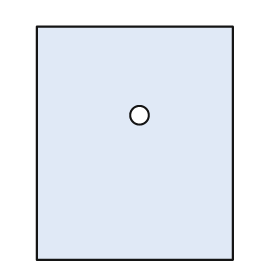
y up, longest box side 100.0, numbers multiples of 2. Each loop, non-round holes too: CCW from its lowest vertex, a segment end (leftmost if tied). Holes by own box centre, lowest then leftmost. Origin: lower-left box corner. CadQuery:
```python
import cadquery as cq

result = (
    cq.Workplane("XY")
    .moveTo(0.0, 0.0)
    .lineTo(84.0, 0.0)
    .lineTo(84.0, 100.0)
    .lineTo(0.0, 100.0)
    .close()
    .moveTo(44.0, 62.0)
    .circle(4.0)
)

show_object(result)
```